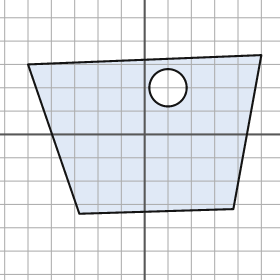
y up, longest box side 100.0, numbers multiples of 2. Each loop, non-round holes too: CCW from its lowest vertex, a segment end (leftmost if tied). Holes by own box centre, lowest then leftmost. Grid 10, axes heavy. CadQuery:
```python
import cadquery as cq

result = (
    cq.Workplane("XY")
    .moveTo(-28.0, -34.0)
    .lineTo(38.0, -32.0)
    .lineTo(50.0, 34.0)
    .lineTo(-50.0, 30.0)
    .close()
    .moveTo(10.0, 20.0)
    .circle(8.0)
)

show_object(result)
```